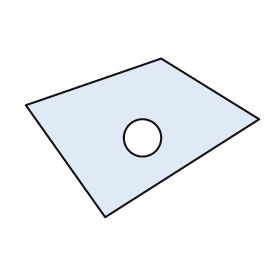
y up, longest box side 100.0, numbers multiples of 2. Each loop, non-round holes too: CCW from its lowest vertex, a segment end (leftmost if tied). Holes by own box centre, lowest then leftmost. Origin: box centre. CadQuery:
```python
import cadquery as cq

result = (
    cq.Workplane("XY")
    .moveTo(-16.0, -34.0)
    .lineTo(50.0, 8.0)
    .lineTo(8.0, 34.0)
    .lineTo(-50.0, 14.0)
    .close()
    .moveTo(0.0, 0.0)
    .circle(8.0)
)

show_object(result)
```